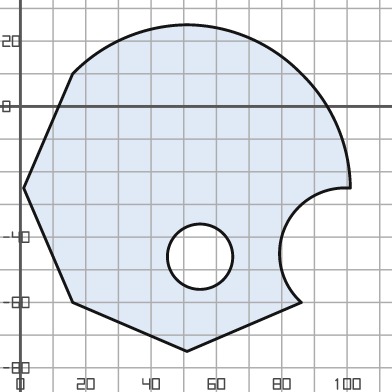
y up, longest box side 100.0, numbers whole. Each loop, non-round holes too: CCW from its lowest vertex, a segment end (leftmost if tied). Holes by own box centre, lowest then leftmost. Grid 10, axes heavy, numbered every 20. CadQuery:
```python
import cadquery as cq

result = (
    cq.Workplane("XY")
    .moveTo(51.0, -75.0)
    .lineTo(86.0, -60.0)
    .threePointArc((81.0, -37.0), (101.0, -25.0))
    .threePointArc((97.0, -6.0), (86.0, 10.0))
    .threePointArc((70.0, 21.0), (51.0, 25.0))
    .threePointArc((32.0, 21.0), (16.0, 10.0))
    .lineTo(1.0, -25.0)
    .lineTo(16.0, -60.0)
    .close()
    .moveTo(55.0, -46.0)
    .circle(10.0)
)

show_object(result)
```